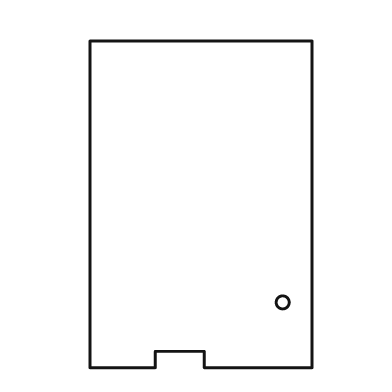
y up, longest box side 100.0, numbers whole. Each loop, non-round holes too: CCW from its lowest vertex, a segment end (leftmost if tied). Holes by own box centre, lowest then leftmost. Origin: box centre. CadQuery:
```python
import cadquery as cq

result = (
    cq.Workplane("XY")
    .moveTo(-34.0, -50.0)
    .lineTo(-14.0, -50.0)
    .lineTo(-14.0, -45.0)
    .lineTo(1.0, -45.0)
    .lineTo(1.0, -50.0)
    .lineTo(34.0, -50.0)
    .lineTo(34.0, 50.0)
    .lineTo(-34.0, 50.0)
    .close()
    .moveTo(25.0, -30.0)
    .circle(2.0)
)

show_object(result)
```